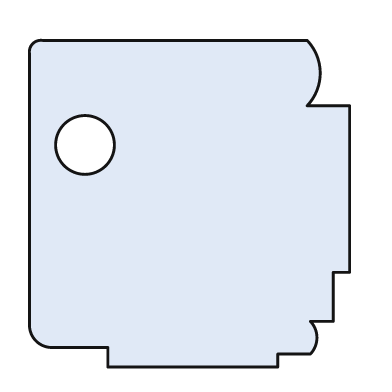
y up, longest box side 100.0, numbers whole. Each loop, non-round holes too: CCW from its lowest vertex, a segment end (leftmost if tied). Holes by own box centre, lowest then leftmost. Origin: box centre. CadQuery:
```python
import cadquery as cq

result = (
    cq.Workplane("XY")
    .moveTo(-25.0, -50.0)
    .lineTo(27.0, -50.0)
    .lineTo(27.0, -46.0)
    .lineTo(37.0, -46.0)
    .threePointArc((39.0, -41.0), (37.0, -36.0))
    .lineTo(44.0, -36.0)
    .lineTo(44.0, -21.0)
    .lineTo(49.0, -21.0)
    .lineTo(49.0, 30.0)
    .lineTo(36.0, 30.0)
    .threePointArc((40.0, 40.0), (36.0, 50.0))
    .lineTo(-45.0, 50.0)
    .threePointArc((-48.0, 49.0), (-49.0, 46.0))
    .lineTo(-49.0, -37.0)
    .threePointArc((-47.0, -42.0), (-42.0, -44.0))
    .lineTo(-25.0, -44.0)
    .close()
    .moveTo(-32.0, 18.0)
    .circle(9.0)
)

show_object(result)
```